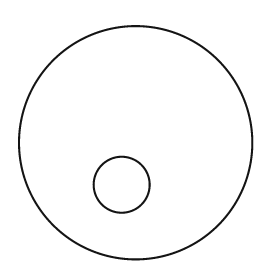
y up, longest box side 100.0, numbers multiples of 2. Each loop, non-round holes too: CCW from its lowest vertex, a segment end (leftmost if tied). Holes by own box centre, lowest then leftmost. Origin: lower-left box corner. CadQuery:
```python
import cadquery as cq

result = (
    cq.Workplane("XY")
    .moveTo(50.0, 50.0)
    .circle(50.0)
    .moveTo(44.0, 32.0)
    .circle(12.0)
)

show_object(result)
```